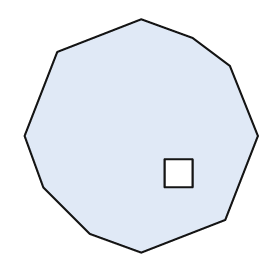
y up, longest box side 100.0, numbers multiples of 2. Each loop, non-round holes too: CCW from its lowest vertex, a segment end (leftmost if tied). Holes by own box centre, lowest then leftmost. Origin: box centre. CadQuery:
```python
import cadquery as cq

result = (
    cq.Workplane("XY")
    .moveTo(0.0, -50.0)
    .lineTo(36.0, -36.0)
    .lineTo(50.0, 0.0)
    .lineTo(38.0, 30.0)
    .lineTo(22.0, 42.0)
    .lineTo(0.0, 50.0)
    .lineTo(-36.0, 36.0)
    .lineTo(-50.0, 0.0)
    .lineTo(-42.0, -22.0)
    .lineTo(-22.0, -42.0)
    .close()
    .moveTo(10.0, -22.0)
    .lineTo(22.0, -22.0)
    .lineTo(22.0, -10.0)
    .lineTo(10.0, -10.0)
    .close()
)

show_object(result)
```